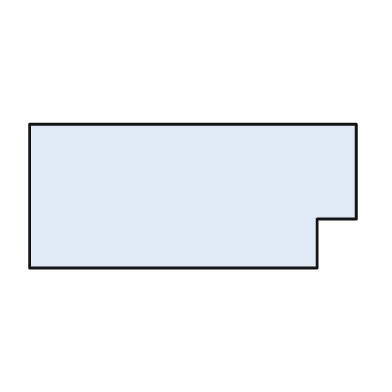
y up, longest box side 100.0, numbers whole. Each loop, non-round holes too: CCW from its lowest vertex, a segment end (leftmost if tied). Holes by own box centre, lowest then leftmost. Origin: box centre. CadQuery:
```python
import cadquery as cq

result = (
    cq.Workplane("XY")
    .moveTo(-50.0, -22.0)
    .lineTo(38.0, -22.0)
    .lineTo(38.0, -7.0)
    .lineTo(50.0, -7.0)
    .lineTo(50.0, 22.0)
    .lineTo(-50.0, 22.0)
    .close()
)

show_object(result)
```